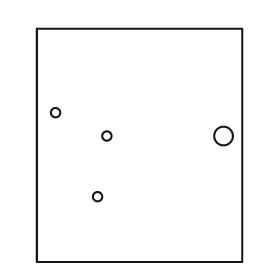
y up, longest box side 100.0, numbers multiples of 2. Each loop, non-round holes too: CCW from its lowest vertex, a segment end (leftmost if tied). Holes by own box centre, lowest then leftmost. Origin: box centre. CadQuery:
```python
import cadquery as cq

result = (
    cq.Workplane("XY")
    .moveTo(-44.0, -50.0)
    .lineTo(44.0, -50.0)
    .lineTo(44.0, 50.0)
    .lineTo(-44.0, 50.0)
    .close()
    .moveTo(-18.0, -22.0)
    .circle(2.0)
    .moveTo(-14.0, 4.0)
    .circle(2.0)
    .moveTo(36.0, 4.0)
    .circle(4.0)
    .moveTo(-36.0, 14.0)
    .circle(2.0)
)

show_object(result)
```